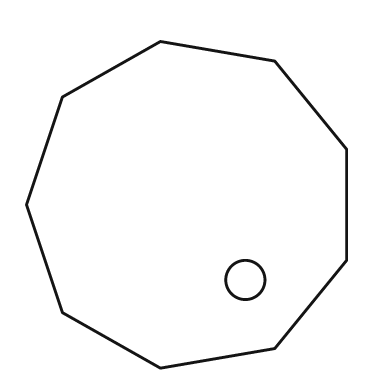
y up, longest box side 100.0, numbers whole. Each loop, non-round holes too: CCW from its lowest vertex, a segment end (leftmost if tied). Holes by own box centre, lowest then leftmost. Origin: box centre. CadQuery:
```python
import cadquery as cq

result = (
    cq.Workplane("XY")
    .moveTo(-8.0, -50.0)
    .lineTo(27.0, -44.0)
    .lineTo(49.0, -17.0)
    .lineTo(49.0, 17.0)
    .lineTo(27.0, 44.0)
    .lineTo(-8.0, 50.0)
    .lineTo(-38.0, 33.0)
    .lineTo(-49.0, 0.0)
    .lineTo(-38.0, -33.0)
    .close()
    .moveTo(18.0, -23.0)
    .circle(6.0)
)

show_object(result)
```